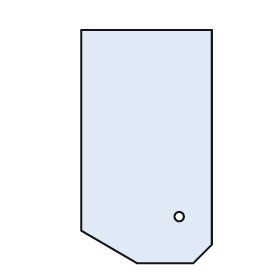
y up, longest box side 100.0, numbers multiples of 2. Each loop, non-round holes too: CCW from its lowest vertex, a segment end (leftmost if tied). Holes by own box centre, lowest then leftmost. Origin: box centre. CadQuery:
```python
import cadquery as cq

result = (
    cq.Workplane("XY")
    .moveTo(-4.0, -50.0)
    .lineTo(20.0, -50.0)
    .lineTo(28.0, -42.0)
    .lineTo(28.0, 50.0)
    .lineTo(-28.0, 50.0)
    .lineTo(-28.0, -36.0)
    .close()
    .moveTo(14.0, -30.0)
    .circle(2.0)
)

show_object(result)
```